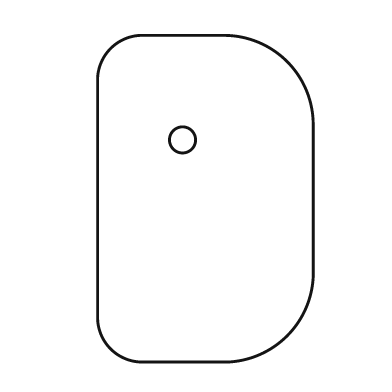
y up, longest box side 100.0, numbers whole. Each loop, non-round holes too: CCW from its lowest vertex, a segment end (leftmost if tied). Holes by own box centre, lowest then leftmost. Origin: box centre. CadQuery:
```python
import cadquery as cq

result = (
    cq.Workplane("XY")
    .moveTo(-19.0, -50.0)
    .lineTo(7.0, -50.0)
    .threePointArc((25.0, -42.0), (33.0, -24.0))
    .lineTo(33.0, 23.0)
    .threePointArc((25.0, 42.0), (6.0, 50.0))
    .lineTo(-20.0, 50.0)
    .threePointArc((-29.0, 46.0), (-33.0, 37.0))
    .lineTo(-33.0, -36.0)
    .threePointArc((-29.0, -46.0), (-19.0, -50.0))
    .close()
    .moveTo(-7.0, 18.0)
    .circle(4.0)
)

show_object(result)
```